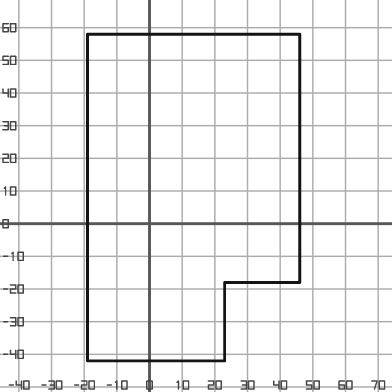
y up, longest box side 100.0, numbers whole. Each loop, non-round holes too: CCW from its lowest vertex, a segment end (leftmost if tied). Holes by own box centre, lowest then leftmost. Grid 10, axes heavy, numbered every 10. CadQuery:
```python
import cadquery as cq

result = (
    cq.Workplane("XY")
    .moveTo(-19.0, -42.0)
    .lineTo(23.0, -42.0)
    .lineTo(23.0, -18.0)
    .lineTo(46.0, -18.0)
    .lineTo(46.0, 58.0)
    .lineTo(-19.0, 58.0)
    .close()
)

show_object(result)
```